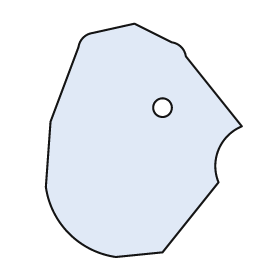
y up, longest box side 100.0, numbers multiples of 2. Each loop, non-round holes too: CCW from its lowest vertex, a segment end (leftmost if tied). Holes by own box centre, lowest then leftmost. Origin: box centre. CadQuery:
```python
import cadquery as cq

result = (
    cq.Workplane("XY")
    .moveTo(-12.0, -50.0)
    .lineTo(8.0, -48.0)
    .lineTo(32.0, -18.0)
    .threePointArc((32.0, -4.0), (42.0, 6.0))
    .lineTo(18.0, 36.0)
    .threePointArc((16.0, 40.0), (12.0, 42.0))
    .lineTo(-4.0, 50.0)
    .lineTo(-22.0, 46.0)
    .threePointArc((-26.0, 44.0), (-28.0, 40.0))
    .lineTo(-40.0, 8.0)
    .lineTo(-42.0, -20.0)
    .threePointArc((-32.0, -40.0), (-12.0, -50.0))
    .close()
    .moveTo(8.0, 14.0)
    .circle(4.0)
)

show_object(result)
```